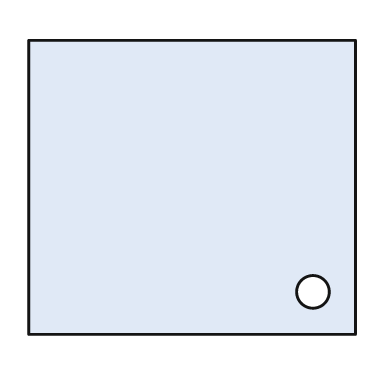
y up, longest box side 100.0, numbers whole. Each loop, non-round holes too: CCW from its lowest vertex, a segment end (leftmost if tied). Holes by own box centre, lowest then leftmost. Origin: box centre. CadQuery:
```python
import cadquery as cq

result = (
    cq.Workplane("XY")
    .moveTo(-50.0, -45.0)
    .lineTo(50.0, -45.0)
    .lineTo(50.0, 45.0)
    .lineTo(-50.0, 45.0)
    .close()
    .moveTo(37.0, -32.0)
    .circle(5.0)
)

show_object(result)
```